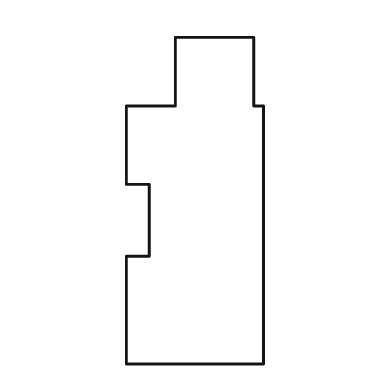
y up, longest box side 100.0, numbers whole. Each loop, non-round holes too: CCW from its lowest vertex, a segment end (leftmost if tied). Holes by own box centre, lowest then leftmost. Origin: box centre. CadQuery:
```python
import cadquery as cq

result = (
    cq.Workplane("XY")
    .moveTo(-21.0, -50.0)
    .lineTo(21.0, -50.0)
    .lineTo(21.0, 29.0)
    .lineTo(18.0, 29.0)
    .lineTo(18.0, 50.0)
    .lineTo(-6.0, 50.0)
    .lineTo(-6.0, 29.0)
    .lineTo(-21.0, 29.0)
    .lineTo(-21.0, 5.0)
    .lineTo(-14.0, 5.0)
    .lineTo(-14.0, -17.0)
    .lineTo(-21.0, -17.0)
    .close()
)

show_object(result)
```